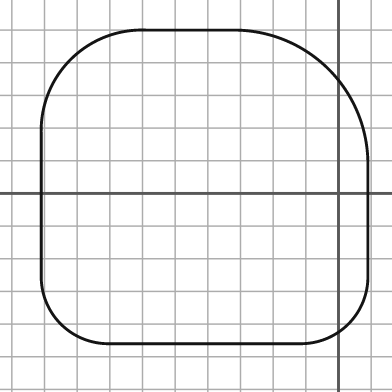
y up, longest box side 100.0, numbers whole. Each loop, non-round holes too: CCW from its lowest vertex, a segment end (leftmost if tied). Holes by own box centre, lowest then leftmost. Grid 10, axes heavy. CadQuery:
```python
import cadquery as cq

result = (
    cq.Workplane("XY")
    .moveTo(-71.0, -46.0)
    .lineTo(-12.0, -46.0)
    .threePointArc((3.0, -40.0), (9.0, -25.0))
    .lineTo(9.0, 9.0)
    .threePointArc((-3.0, 38.0), (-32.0, 50.0))
    .lineTo(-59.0, 50.0)
    .threePointArc((-82.0, 41.0), (-91.0, 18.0))
    .lineTo(-91.0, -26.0)
    .threePointArc((-85.0, -40.0), (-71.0, -46.0))
    .close()
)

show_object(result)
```